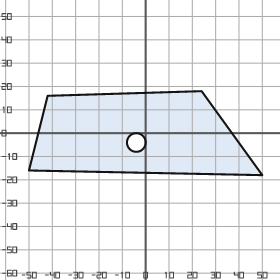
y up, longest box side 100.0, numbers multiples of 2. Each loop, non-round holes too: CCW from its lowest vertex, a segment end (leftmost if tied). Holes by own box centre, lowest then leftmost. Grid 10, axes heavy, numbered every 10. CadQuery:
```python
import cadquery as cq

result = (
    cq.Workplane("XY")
    .moveTo(50.0, -18.0)
    .lineTo(24.0, 18.0)
    .lineTo(-42.0, 16.0)
    .lineTo(-50.0, -16.0)
    .close()
    .moveTo(-4.0, -4.0)
    .circle(4.0)
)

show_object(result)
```